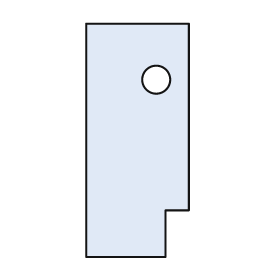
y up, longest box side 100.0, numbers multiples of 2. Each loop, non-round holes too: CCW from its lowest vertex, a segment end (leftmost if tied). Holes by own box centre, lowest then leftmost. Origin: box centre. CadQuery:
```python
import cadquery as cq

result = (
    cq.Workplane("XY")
    .moveTo(-22.0, -50.0)
    .lineTo(12.0, -50.0)
    .lineTo(12.0, -30.0)
    .lineTo(22.0, -30.0)
    .lineTo(22.0, 50.0)
    .lineTo(-22.0, 50.0)
    .close()
    .moveTo(8.0, 26.0)
    .circle(6.0)
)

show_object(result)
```